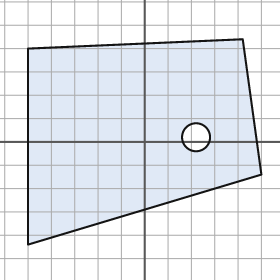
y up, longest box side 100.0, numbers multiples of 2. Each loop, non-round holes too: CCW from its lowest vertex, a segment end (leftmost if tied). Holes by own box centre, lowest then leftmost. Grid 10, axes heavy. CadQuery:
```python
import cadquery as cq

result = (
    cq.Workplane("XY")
    .moveTo(-50.0, -44.0)
    .lineTo(50.0, -14.0)
    .lineTo(42.0, 44.0)
    .lineTo(-50.0, 40.0)
    .close()
    .moveTo(22.0, 2.0)
    .circle(6.0)
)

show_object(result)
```